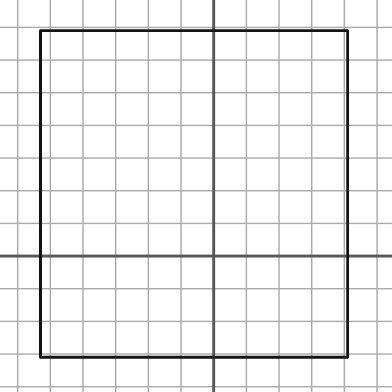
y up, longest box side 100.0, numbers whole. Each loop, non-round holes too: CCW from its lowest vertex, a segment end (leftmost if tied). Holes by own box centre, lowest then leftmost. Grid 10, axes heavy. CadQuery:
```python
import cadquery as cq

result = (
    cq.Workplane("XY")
    .moveTo(-53.0, -31.0)
    .lineTo(41.0, -31.0)
    .lineTo(41.0, 69.0)
    .lineTo(-53.0, 69.0)
    .close()
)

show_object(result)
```